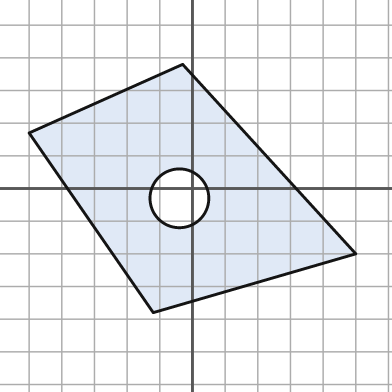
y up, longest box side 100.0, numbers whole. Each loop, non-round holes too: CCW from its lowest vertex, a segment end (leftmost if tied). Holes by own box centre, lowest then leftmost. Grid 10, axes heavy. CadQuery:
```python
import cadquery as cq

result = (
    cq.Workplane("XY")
    .moveTo(-12.0, -38.0)
    .lineTo(50.0, -20.0)
    .lineTo(-3.0, 38.0)
    .lineTo(-50.0, 17.0)
    .close()
    .moveTo(-4.0, -3.0)
    .circle(9.0)
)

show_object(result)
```